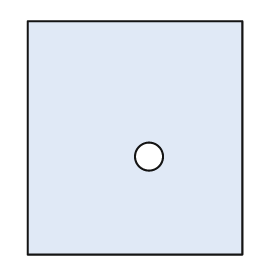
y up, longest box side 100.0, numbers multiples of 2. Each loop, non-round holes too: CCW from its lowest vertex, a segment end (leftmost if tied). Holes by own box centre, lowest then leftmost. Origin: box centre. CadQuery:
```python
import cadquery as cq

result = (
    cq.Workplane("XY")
    .moveTo(-46.0, -50.0)
    .lineTo(46.0, -50.0)
    .lineTo(46.0, 50.0)
    .lineTo(-46.0, 50.0)
    .close()
    .moveTo(6.0, -8.0)
    .circle(6.0)
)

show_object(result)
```